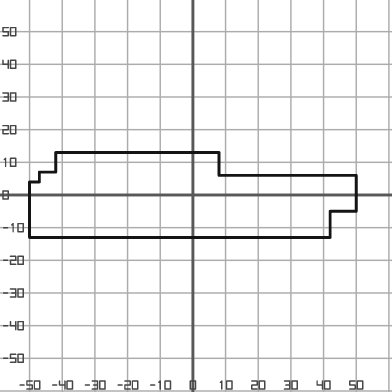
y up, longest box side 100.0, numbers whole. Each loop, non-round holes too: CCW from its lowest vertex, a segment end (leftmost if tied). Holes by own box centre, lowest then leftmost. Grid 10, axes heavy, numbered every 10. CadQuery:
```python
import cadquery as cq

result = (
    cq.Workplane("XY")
    .moveTo(-50.0, -13.0)
    .lineTo(42.0, -13.0)
    .lineTo(42.0, -5.0)
    .lineTo(50.0, -5.0)
    .lineTo(50.0, 6.0)
    .lineTo(8.0, 6.0)
    .lineTo(8.0, 13.0)
    .lineTo(-42.0, 13.0)
    .lineTo(-42.0, 7.0)
    .lineTo(-47.0, 7.0)
    .lineTo(-47.0, 4.0)
    .lineTo(-50.0, 4.0)
    .close()
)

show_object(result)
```